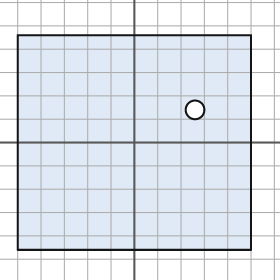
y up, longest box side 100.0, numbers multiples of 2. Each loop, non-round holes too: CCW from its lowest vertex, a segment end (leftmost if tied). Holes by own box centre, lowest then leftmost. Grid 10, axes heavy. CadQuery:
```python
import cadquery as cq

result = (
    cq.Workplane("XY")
    .moveTo(-50.0, -46.0)
    .lineTo(50.0, -46.0)
    .lineTo(50.0, 46.0)
    .lineTo(-50.0, 46.0)
    .close()
    .moveTo(26.0, 14.0)
    .circle(4.0)
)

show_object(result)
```